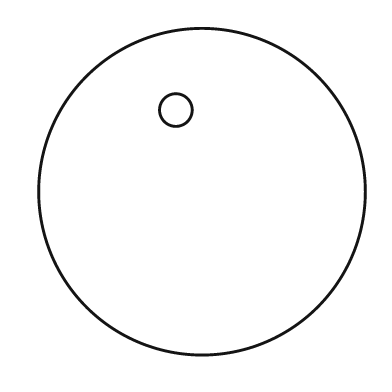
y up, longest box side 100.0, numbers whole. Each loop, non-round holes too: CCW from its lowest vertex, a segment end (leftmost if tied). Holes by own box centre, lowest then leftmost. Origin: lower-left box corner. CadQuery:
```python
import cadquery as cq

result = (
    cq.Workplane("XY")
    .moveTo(50.0, 50.0)
    .circle(50.0)
    .moveTo(42.0, 75.0)
    .circle(5.0)
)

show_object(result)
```